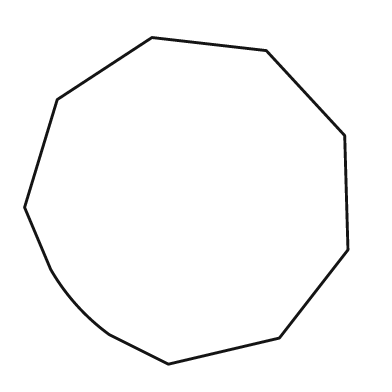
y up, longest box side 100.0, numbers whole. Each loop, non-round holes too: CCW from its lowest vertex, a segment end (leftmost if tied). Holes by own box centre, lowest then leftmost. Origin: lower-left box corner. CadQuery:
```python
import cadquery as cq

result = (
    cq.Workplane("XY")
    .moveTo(44.0, 0.0)
    .lineTo(78.0, 8.0)
    .lineTo(99.0, 35.0)
    .lineTo(98.0, 70.0)
    .lineTo(74.0, 96.0)
    .lineTo(39.0, 100.0)
    .lineTo(10.0, 81.0)
    .lineTo(0.0, 48.0)
    .lineTo(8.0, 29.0)
    .threePointArc((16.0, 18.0), (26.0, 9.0))
    .close()
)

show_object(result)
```